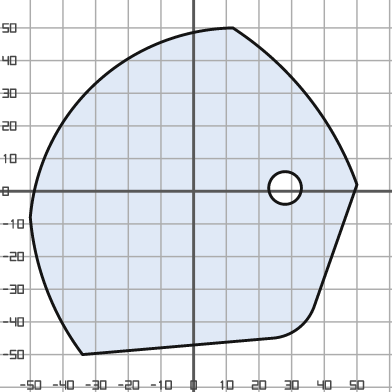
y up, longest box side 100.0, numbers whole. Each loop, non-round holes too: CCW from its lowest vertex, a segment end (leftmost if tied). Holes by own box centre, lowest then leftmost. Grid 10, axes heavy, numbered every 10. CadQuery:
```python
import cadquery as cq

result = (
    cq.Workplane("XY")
    .moveTo(-34.0, -50.0)
    .lineTo(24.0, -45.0)
    .threePointArc((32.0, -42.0), (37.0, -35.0))
    .lineTo(50.0, 2.0)
    .threePointArc((35.0, 29.0), (12.0, 50.0))
    .threePointArc((-30.0, 33.0), (-50.0, -8.0))
    .threePointArc((-45.0, -30.0), (-34.0, -50.0))
    .close()
    .moveTo(28.0, 1.0)
    .circle(5.0)
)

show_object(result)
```